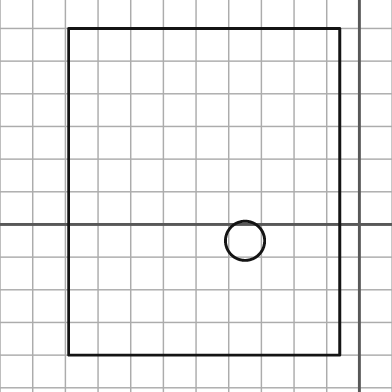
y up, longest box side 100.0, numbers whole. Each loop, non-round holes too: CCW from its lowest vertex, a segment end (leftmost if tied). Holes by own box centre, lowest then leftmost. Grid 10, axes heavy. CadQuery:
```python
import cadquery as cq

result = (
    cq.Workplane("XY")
    .moveTo(-89.0, -40.0)
    .lineTo(-6.0, -40.0)
    .lineTo(-6.0, 60.0)
    .lineTo(-89.0, 60.0)
    .close()
    .moveTo(-35.0, -5.0)
    .circle(6.0)
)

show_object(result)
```